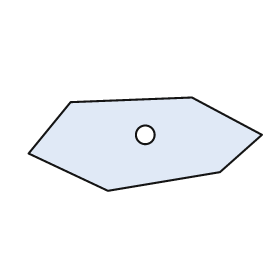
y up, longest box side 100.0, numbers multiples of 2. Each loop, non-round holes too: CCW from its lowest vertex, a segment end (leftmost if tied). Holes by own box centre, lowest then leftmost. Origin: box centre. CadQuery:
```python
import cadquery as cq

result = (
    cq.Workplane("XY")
    .moveTo(-16.0, -20.0)
    .lineTo(32.0, -12.0)
    .lineTo(50.0, 4.0)
    .lineTo(20.0, 20.0)
    .lineTo(-32.0, 18.0)
    .lineTo(-50.0, -4.0)
    .close()
    .moveTo(0.0, 4.0)
    .circle(4.0)
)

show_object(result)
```